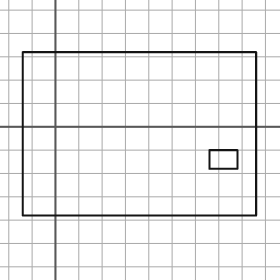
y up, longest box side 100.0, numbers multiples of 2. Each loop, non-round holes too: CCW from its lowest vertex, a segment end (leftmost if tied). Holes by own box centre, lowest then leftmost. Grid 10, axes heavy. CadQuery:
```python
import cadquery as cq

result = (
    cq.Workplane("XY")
    .moveTo(-14.0, -38.0)
    .lineTo(86.0, -38.0)
    .lineTo(86.0, 32.0)
    .lineTo(-14.0, 32.0)
    .close()
    .moveTo(66.0, -18.0)
    .lineTo(78.0, -18.0)
    .lineTo(78.0, -10.0)
    .lineTo(66.0, -10.0)
    .close()
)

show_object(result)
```